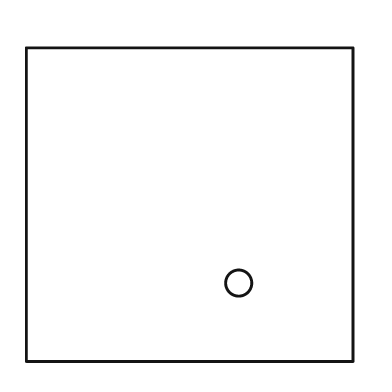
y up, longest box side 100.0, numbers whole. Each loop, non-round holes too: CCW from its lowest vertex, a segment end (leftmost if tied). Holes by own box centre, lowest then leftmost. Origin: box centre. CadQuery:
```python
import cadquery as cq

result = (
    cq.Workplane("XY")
    .moveTo(-50.0, -48.0)
    .lineTo(50.0, -48.0)
    .lineTo(50.0, 48.0)
    .lineTo(-50.0, 48.0)
    .close()
    .moveTo(15.0, -24.0)
    .circle(4.0)
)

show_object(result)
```